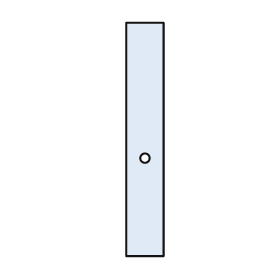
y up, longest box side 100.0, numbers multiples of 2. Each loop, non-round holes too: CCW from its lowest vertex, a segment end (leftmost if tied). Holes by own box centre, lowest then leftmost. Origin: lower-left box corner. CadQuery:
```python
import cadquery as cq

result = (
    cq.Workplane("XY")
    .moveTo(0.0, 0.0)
    .lineTo(16.0, 0.0)
    .lineTo(16.0, 100.0)
    .lineTo(0.0, 100.0)
    .close()
    .moveTo(8.0, 42.0)
    .circle(2.0)
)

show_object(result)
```